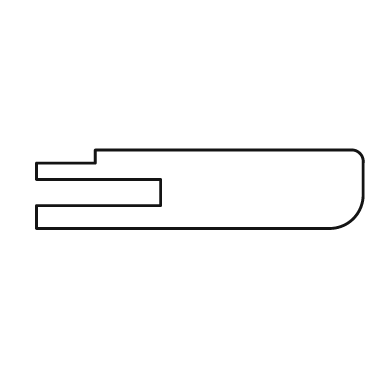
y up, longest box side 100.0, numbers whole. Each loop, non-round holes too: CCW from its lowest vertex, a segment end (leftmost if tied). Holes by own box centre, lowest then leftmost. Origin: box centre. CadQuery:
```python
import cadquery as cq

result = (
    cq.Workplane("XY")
    .moveTo(-50.0, -12.0)
    .lineTo(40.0, -12.0)
    .threePointArc((47.0, -9.0), (50.0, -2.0))
    .lineTo(50.0, 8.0)
    .threePointArc((49.0, 11.0), (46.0, 12.0))
    .lineTo(-32.0, 12.0)
    .lineTo(-32.0, 8.0)
    .lineTo(-50.0, 8.0)
    .lineTo(-50.0, 3.0)
    .lineTo(-12.0, 3.0)
    .lineTo(-12.0, -5.0)
    .lineTo(-50.0, -5.0)
    .close()
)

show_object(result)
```